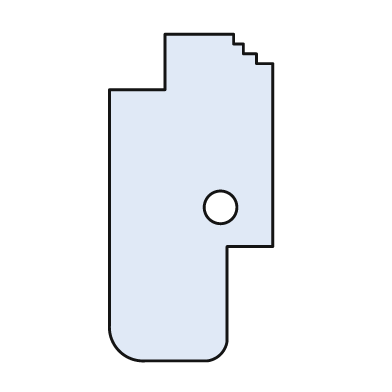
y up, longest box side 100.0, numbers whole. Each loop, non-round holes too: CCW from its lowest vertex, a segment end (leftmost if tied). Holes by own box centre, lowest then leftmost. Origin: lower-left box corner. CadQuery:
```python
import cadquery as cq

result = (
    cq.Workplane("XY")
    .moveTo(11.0, 0.0)
    .lineTo(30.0, 0.0)
    .threePointArc((34.0, 2.0), (36.0, 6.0))
    .lineTo(36.0, 35.0)
    .lineTo(50.0, 35.0)
    .lineTo(50.0, 91.0)
    .lineTo(45.0, 91.0)
    .lineTo(45.0, 94.0)
    .lineTo(41.0, 94.0)
    .lineTo(41.0, 97.0)
    .lineTo(38.0, 97.0)
    .lineTo(38.0, 100.0)
    .lineTo(17.0, 100.0)
    .lineTo(17.0, 83.0)
    .lineTo(0.0, 83.0)
    .lineTo(0.0, 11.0)
    .threePointArc((3.0, 3.0), (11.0, 0.0))
    .close()
    .moveTo(34.0, 47.0)
    .circle(5.0)
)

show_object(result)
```